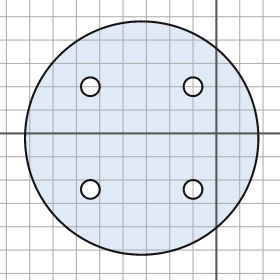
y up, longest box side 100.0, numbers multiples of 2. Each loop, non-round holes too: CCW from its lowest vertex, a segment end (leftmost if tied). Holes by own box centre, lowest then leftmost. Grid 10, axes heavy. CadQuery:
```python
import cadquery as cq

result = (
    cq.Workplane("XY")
    .moveTo(-32.0, -2.0)
    .circle(50.0)
    .moveTo(-54.0, -24.0)
    .circle(4.0)
    .moveTo(-10.0, -24.0)
    .circle(4.0)
    .moveTo(-54.0, 20.0)
    .circle(4.0)
    .moveTo(-10.0, 20.0)
    .circle(4.0)
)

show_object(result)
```